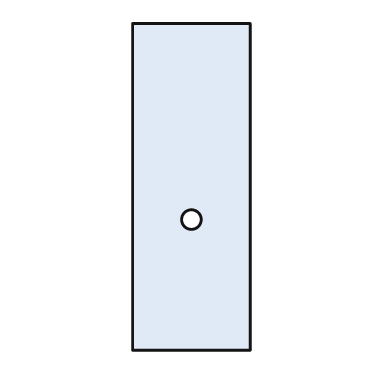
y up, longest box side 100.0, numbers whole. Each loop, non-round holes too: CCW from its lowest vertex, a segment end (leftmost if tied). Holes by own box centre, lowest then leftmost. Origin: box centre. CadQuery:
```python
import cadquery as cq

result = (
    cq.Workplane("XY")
    .moveTo(-18.0, -50.0)
    .lineTo(18.0, -50.0)
    .lineTo(18.0, 50.0)
    .lineTo(-18.0, 50.0)
    .close()
    .moveTo(0.0, -10.0)
    .circle(3.0)
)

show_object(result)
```